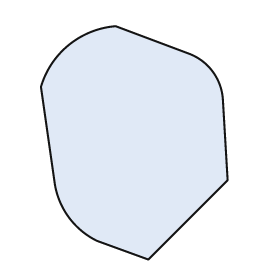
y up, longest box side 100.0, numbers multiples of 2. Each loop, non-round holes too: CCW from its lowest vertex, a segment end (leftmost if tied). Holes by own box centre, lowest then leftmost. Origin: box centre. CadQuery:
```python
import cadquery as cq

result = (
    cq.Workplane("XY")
    .moveTo(6.0, -50.0)
    .lineTo(40.0, -16.0)
    .lineTo(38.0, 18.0)
    .threePointArc((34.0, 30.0), (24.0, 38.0))
    .lineTo(-8.0, 50.0)
    .threePointArc((-28.0, 42.0), (-40.0, 24.0))
    .lineTo(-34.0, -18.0)
    .threePointArc((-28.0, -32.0), (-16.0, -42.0))
    .close()
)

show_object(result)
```